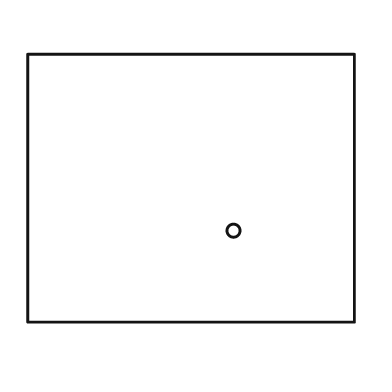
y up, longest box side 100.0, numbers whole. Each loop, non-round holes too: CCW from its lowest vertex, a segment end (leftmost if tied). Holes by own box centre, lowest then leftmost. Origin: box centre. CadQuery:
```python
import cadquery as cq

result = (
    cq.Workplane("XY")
    .moveTo(-50.0, -41.0)
    .lineTo(50.0, -41.0)
    .lineTo(50.0, 41.0)
    .lineTo(-50.0, 41.0)
    .close()
    .moveTo(13.0, -13.0)
    .circle(2.0)
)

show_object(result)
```